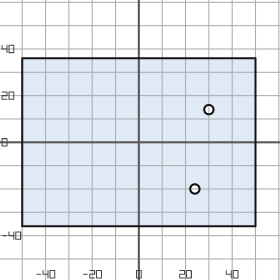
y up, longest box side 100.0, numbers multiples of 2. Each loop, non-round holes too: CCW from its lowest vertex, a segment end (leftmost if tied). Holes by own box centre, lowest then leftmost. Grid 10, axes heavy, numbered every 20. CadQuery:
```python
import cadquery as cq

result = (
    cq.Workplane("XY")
    .moveTo(-50.0, -36.0)
    .lineTo(50.0, -36.0)
    .lineTo(50.0, 36.0)
    .lineTo(-50.0, 36.0)
    .close()
    .moveTo(24.0, -20.0)
    .circle(2.0)
    .moveTo(30.0, 14.0)
    .circle(2.0)
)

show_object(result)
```